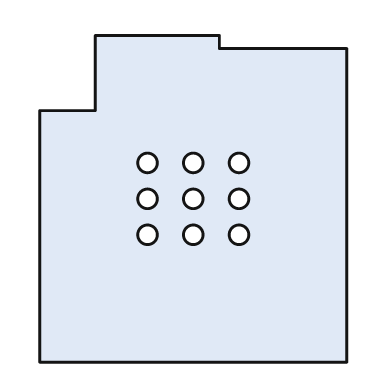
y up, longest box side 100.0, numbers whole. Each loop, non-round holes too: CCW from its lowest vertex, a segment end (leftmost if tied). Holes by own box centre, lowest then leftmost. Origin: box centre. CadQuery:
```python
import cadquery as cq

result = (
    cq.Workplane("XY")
    .moveTo(-47.0, -50.0)
    .lineTo(47.0, -50.0)
    .lineTo(47.0, 46.0)
    .lineTo(8.0, 46.0)
    .lineTo(8.0, 50.0)
    .lineTo(-30.0, 50.0)
    .lineTo(-30.0, 27.0)
    .lineTo(-47.0, 27.0)
    .close()
    .moveTo(-14.0, -11.0)
    .circle(3.0)
    .moveTo(0.0, -11.0)
    .circle(3.0)
    .moveTo(14.0, -11.0)
    .circle(3.0)
    .moveTo(-14.0, 0.0)
    .circle(3.0)
    .moveTo(0.0, 0.0)
    .circle(3.0)
    .moveTo(14.0, 0.0)
    .circle(3.0)
    .moveTo(-14.0, 11.0)
    .circle(3.0)
    .moveTo(0.0, 11.0)
    .circle(3.0)
    .moveTo(14.0, 11.0)
    .circle(3.0)
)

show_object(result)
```